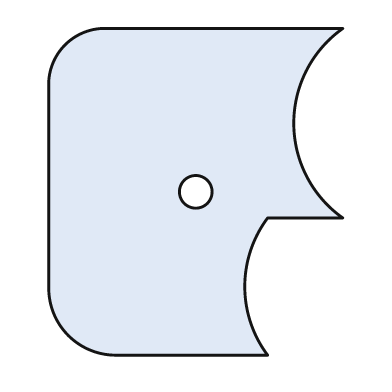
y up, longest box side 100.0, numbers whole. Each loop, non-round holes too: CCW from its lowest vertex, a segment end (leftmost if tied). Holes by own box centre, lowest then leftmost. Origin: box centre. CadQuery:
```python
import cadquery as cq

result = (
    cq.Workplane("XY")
    .moveTo(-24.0, -50.0)
    .lineTo(22.0, -50.0)
    .threePointArc((15.0, -29.0), (22.0, -8.0))
    .lineTo(45.0, -8.0)
    .threePointArc((30.0, 21.0), (45.0, 50.0))
    .lineTo(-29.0, 50.0)
    .threePointArc((-40.0, 45.0), (-45.0, 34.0))
    .lineTo(-45.0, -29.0)
    .threePointArc((-39.0, -44.0), (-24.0, -50.0))
    .close()
    .moveTo(0.0, 0.0)
    .circle(5.0)
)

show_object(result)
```